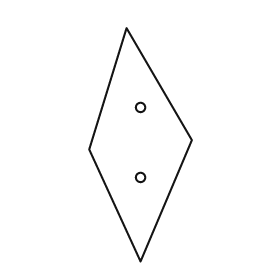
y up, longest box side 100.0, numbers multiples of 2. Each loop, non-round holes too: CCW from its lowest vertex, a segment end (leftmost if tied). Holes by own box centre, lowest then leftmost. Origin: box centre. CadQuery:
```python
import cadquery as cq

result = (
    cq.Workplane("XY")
    .moveTo(0.0, -50.0)
    .lineTo(22.0, 2.0)
    .lineTo(-6.0, 50.0)
    .lineTo(-22.0, -2.0)
    .close()
    .moveTo(0.0, -14.0)
    .circle(2.0)
    .moveTo(0.0, 16.0)
    .circle(2.0)
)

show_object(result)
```